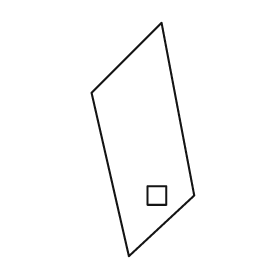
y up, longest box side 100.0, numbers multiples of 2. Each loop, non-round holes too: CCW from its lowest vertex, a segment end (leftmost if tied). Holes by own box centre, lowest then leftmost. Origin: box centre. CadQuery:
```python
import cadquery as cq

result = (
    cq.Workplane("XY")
    .moveTo(-6.0, -50.0)
    .lineTo(22.0, -24.0)
    .lineTo(8.0, 50.0)
    .lineTo(-22.0, 20.0)
    .close()
    .moveTo(2.0, -28.0)
    .lineTo(10.0, -28.0)
    .lineTo(10.0, -20.0)
    .lineTo(2.0, -20.0)
    .close()
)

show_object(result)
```